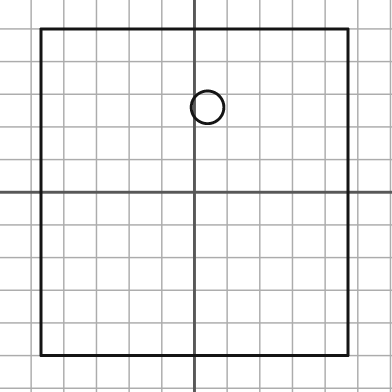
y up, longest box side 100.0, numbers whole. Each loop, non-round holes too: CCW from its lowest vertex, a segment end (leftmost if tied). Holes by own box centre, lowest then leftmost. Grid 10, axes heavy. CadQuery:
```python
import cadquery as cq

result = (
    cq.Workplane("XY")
    .moveTo(-47.0, -50.0)
    .lineTo(47.0, -50.0)
    .lineTo(47.0, 50.0)
    .lineTo(-47.0, 50.0)
    .close()
    .moveTo(4.0, 26.0)
    .circle(5.0)
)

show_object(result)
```